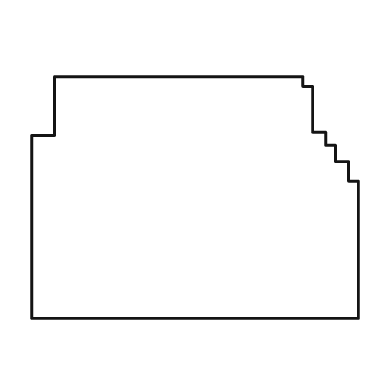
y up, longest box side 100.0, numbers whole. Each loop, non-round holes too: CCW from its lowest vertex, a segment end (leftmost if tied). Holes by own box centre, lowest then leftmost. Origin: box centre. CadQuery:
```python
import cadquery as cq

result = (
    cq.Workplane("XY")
    .moveTo(-50.0, -37.0)
    .lineTo(50.0, -37.0)
    .lineTo(50.0, 5.0)
    .lineTo(47.0, 5.0)
    .lineTo(47.0, 11.0)
    .lineTo(43.0, 11.0)
    .lineTo(43.0, 16.0)
    .lineTo(40.0, 16.0)
    .lineTo(40.0, 20.0)
    .lineTo(36.0, 20.0)
    .lineTo(36.0, 34.0)
    .lineTo(33.0, 34.0)
    .lineTo(33.0, 37.0)
    .lineTo(-43.0, 37.0)
    .lineTo(-43.0, 19.0)
    .lineTo(-50.0, 19.0)
    .close()
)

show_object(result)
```